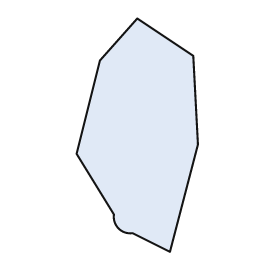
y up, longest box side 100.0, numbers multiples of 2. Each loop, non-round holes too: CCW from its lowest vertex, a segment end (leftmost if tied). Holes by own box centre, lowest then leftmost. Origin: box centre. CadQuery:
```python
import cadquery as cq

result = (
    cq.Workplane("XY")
    .moveTo(14.0, -50.0)
    .lineTo(26.0, -4.0)
    .lineTo(24.0, 34.0)
    .lineTo(0.0, 50.0)
    .lineTo(-16.0, 32.0)
    .lineTo(-26.0, -8.0)
    .lineTo(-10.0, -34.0)
    .threePointArc((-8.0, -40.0), (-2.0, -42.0))
    .close()
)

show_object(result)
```